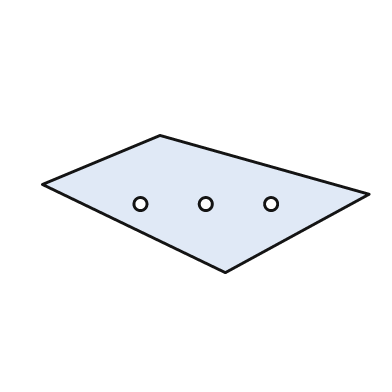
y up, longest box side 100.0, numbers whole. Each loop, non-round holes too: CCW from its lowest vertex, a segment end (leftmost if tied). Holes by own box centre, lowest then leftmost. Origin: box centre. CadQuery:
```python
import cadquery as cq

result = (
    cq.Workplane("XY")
    .moveTo(6.0, -21.0)
    .lineTo(50.0, 3.0)
    .lineTo(-14.0, 21.0)
    .lineTo(-50.0, 6.0)
    .close()
    .moveTo(-20.0, 0.0)
    .circle(2.0)
    .moveTo(0.0, 0.0)
    .circle(2.0)
    .moveTo(20.0, 0.0)
    .circle(2.0)
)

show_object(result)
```